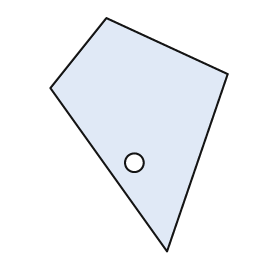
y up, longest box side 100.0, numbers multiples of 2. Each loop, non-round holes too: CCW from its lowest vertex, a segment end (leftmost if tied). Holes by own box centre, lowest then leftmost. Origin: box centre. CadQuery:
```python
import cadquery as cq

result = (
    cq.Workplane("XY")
    .moveTo(12.0, -50.0)
    .lineTo(38.0, 26.0)
    .lineTo(-14.0, 50.0)
    .lineTo(-38.0, 20.0)
    .close()
    .moveTo(-2.0, -12.0)
    .circle(4.0)
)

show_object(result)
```